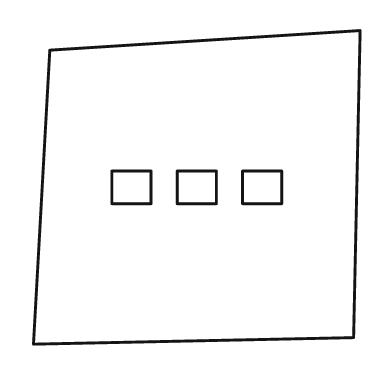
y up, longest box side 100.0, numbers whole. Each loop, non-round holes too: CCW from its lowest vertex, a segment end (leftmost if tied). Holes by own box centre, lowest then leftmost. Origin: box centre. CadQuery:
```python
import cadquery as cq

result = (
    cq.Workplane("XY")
    .moveTo(-50.0, -48.0)
    .lineTo(48.0, -46.0)
    .lineTo(50.0, 48.0)
    .lineTo(-45.0, 42.0)
    .close()
    .moveTo(-26.0, -5.0)
    .lineTo(-14.0, -5.0)
    .lineTo(-14.0, 5.0)
    .lineTo(-26.0, 5.0)
    .close()
    .moveTo(-6.0, -5.0)
    .lineTo(6.0, -5.0)
    .lineTo(6.0, 5.0)
    .lineTo(-6.0, 5.0)
    .close()
    .moveTo(14.0, -5.0)
    .lineTo(26.0, -5.0)
    .lineTo(26.0, 5.0)
    .lineTo(14.0, 5.0)
    .close()
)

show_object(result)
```